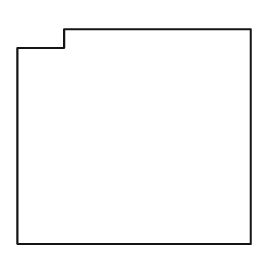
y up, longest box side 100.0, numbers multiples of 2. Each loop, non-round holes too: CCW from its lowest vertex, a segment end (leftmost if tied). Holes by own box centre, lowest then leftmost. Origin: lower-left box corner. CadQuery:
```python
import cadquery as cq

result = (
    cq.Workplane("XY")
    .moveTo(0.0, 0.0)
    .lineTo(100.0, 0.0)
    .lineTo(100.0, 92.0)
    .lineTo(20.0, 92.0)
    .lineTo(20.0, 84.0)
    .lineTo(0.0, 84.0)
    .close()
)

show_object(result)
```